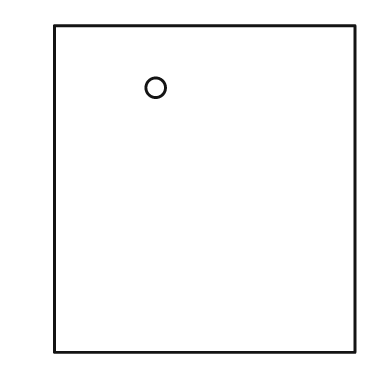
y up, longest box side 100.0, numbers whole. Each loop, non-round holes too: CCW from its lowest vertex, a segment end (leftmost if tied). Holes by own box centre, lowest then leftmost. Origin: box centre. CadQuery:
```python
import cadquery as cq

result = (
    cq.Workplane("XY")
    .moveTo(-46.0, -50.0)
    .lineTo(46.0, -50.0)
    .lineTo(46.0, 50.0)
    .lineTo(-46.0, 50.0)
    .close()
    .moveTo(-15.0, 31.0)
    .circle(3.0)
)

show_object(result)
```